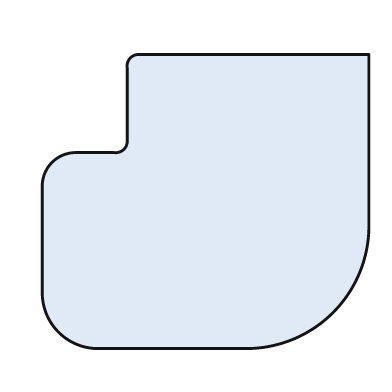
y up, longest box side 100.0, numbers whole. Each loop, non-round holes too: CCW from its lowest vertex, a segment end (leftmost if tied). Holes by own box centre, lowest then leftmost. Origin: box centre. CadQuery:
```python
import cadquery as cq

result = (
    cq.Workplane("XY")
    .moveTo(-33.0, -45.0)
    .lineTo(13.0, -45.0)
    .threePointArc((39.0, -34.0), (50.0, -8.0))
    .lineTo(50.0, 45.0)
    .lineTo(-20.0, 45.0)
    .threePointArc((-23.0, 44.0), (-24.0, 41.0))
    .lineTo(-24.0, 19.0)
    .threePointArc((-25.0, 16.0), (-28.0, 15.0))
    .lineTo(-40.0, 15.0)
    .threePointArc((-47.0, 12.0), (-50.0, 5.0))
    .lineTo(-50.0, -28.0)
    .threePointArc((-45.0, -40.0), (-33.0, -45.0))
    .close()
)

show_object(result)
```